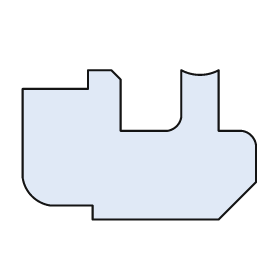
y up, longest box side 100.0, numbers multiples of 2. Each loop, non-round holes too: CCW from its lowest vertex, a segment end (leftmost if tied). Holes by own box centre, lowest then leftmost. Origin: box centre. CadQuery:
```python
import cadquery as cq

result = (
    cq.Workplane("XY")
    .moveTo(-20.0, -32.0)
    .lineTo(34.0, -32.0)
    .lineTo(50.0, -16.0)
    .lineTo(50.0, 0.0)
    .threePointArc((48.0, 4.0), (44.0, 6.0))
    .lineTo(34.0, 6.0)
    .lineTo(34.0, 32.0)
    .threePointArc((26.0, 30.0), (18.0, 32.0))
    .lineTo(18.0, 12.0)
    .threePointArc((16.0, 8.0), (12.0, 6.0))
    .lineTo(-8.0, 6.0)
    .lineTo(-8.0, 28.0)
    .lineTo(-12.0, 32.0)
    .lineTo(-22.0, 32.0)
    .lineTo(-22.0, 24.0)
    .lineTo(-50.0, 24.0)
    .lineTo(-50.0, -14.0)
    .threePointArc((-46.0, -22.0), (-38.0, -26.0))
    .lineTo(-20.0, -26.0)
    .close()
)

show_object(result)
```